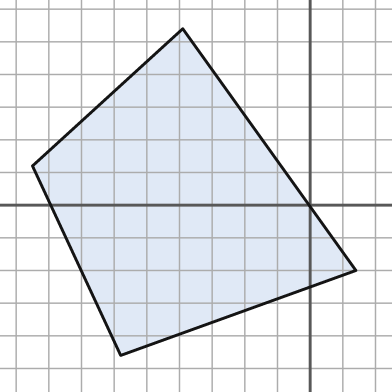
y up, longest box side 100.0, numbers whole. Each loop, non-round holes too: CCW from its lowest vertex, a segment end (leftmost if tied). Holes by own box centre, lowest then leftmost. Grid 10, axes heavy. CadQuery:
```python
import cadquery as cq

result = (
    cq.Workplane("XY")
    .moveTo(-58.0, -46.0)
    .lineTo(14.0, -20.0)
    .lineTo(-39.0, 54.0)
    .lineTo(-85.0, 12.0)
    .close()
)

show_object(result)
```